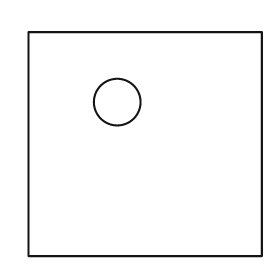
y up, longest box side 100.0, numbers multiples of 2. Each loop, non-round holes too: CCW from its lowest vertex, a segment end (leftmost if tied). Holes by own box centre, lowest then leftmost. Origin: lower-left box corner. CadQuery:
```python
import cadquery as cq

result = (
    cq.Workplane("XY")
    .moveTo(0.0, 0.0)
    .lineTo(100.0, 0.0)
    .lineTo(100.0, 96.0)
    .lineTo(0.0, 96.0)
    .close()
    .moveTo(38.0, 66.0)
    .circle(10.0)
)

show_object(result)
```